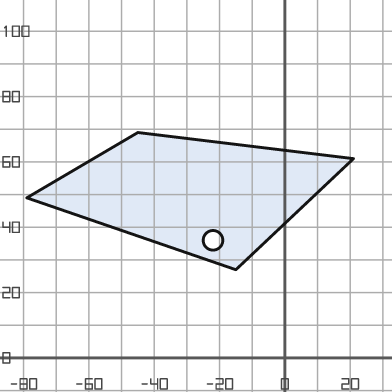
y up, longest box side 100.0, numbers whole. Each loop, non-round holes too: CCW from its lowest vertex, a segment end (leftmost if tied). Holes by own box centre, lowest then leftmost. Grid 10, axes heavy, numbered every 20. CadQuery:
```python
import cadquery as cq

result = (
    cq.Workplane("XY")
    .moveTo(-15.0, 27.0)
    .lineTo(21.0, 61.0)
    .lineTo(-45.0, 69.0)
    .lineTo(-79.0, 49.0)
    .close()
    .moveTo(-22.0, 36.0)
    .circle(3.0)
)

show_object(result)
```